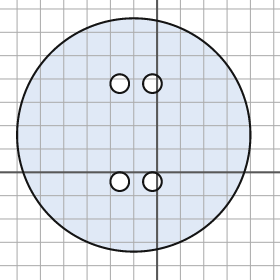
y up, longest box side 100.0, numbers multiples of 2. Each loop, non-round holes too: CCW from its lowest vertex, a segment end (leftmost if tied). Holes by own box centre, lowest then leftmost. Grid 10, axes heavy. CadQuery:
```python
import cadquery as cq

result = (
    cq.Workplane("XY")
    .moveTo(-10.0, 16.0)
    .circle(50.0)
    .moveTo(-16.0, -4.0)
    .circle(4.0)
    .moveTo(-2.0, -4.0)
    .circle(4.0)
    .moveTo(-16.0, 38.0)
    .circle(4.0)
    .moveTo(-2.0, 38.0)
    .circle(4.0)
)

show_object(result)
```